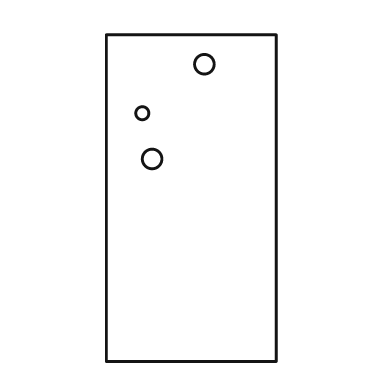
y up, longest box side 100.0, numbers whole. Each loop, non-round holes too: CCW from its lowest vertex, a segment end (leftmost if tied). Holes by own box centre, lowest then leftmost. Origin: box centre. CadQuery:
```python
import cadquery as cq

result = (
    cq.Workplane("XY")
    .moveTo(-26.0, -50.0)
    .lineTo(26.0, -50.0)
    .lineTo(26.0, 50.0)
    .lineTo(-26.0, 50.0)
    .close()
    .moveTo(-12.0, 12.0)
    .circle(3.0)
    .moveTo(-15.0, 26.0)
    .circle(2.0)
    .moveTo(4.0, 41.0)
    .circle(3.0)
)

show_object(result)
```